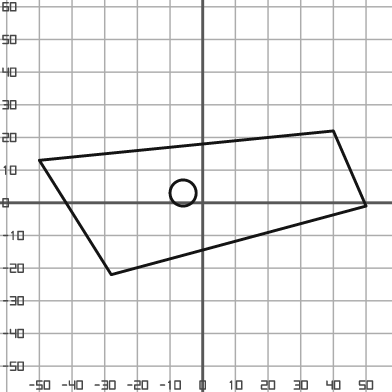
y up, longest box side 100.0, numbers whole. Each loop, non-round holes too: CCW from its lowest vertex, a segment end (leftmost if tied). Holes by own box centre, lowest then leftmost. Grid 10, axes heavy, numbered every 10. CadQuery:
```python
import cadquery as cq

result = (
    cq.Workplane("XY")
    .moveTo(-28.0, -22.0)
    .lineTo(50.0, -1.0)
    .lineTo(40.0, 22.0)
    .lineTo(-50.0, 13.0)
    .close()
    .moveTo(-6.0, 3.0)
    .circle(4.0)
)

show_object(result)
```